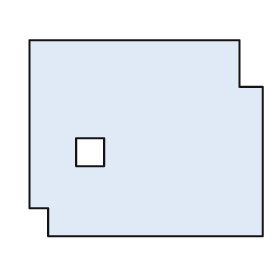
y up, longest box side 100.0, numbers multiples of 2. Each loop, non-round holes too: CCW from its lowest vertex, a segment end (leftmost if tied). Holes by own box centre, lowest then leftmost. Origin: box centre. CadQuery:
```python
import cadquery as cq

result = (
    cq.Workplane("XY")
    .moveTo(-42.0, -42.0)
    .lineTo(50.0, -42.0)
    .lineTo(50.0, 22.0)
    .lineTo(40.0, 22.0)
    .lineTo(40.0, 42.0)
    .lineTo(-50.0, 42.0)
    .lineTo(-50.0, -30.0)
    .lineTo(-42.0, -30.0)
    .close()
    .moveTo(-30.0, -12.0)
    .lineTo(-18.0, -12.0)
    .lineTo(-18.0, 0.0)
    .lineTo(-30.0, 0.0)
    .close()
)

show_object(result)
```